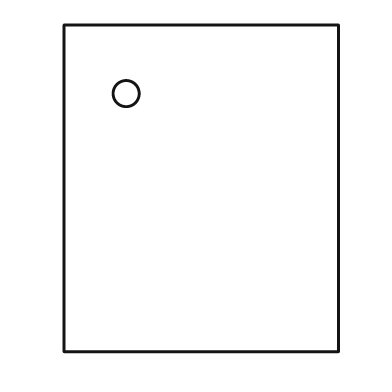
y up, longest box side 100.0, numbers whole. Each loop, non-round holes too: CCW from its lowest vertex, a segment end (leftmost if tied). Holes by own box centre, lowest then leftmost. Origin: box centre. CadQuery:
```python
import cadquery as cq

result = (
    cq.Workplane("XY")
    .moveTo(-42.0, -50.0)
    .lineTo(42.0, -50.0)
    .lineTo(42.0, 50.0)
    .lineTo(-42.0, 50.0)
    .close()
    .moveTo(-23.0, 29.0)
    .circle(4.0)
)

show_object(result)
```